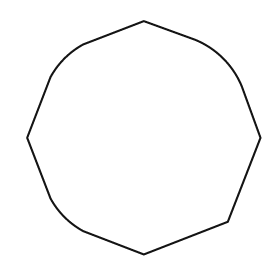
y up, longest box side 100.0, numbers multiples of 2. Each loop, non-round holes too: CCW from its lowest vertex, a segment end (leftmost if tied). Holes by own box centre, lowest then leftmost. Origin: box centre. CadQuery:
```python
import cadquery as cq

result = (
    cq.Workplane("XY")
    .moveTo(0.0, -50.0)
    .lineTo(36.0, -36.0)
    .lineTo(50.0, 0.0)
    .lineTo(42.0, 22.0)
    .threePointArc((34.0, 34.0), (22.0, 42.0))
    .lineTo(0.0, 50.0)
    .lineTo(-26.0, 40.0)
    .threePointArc((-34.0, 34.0), (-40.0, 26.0))
    .lineTo(-50.0, 0.0)
    .lineTo(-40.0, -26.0)
    .threePointArc((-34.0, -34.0), (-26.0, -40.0))
    .close()
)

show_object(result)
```